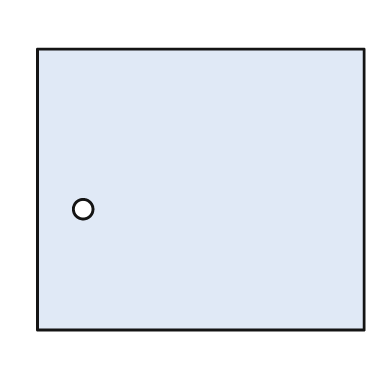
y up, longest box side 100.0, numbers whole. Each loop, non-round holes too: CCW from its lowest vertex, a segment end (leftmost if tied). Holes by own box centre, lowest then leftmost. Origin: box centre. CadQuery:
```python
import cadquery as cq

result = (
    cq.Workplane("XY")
    .moveTo(-50.0, -43.0)
    .lineTo(50.0, -43.0)
    .lineTo(50.0, 43.0)
    .lineTo(-50.0, 43.0)
    .close()
    .moveTo(-36.0, -6.0)
    .circle(3.0)
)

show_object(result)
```